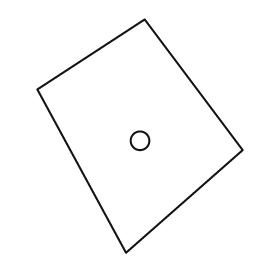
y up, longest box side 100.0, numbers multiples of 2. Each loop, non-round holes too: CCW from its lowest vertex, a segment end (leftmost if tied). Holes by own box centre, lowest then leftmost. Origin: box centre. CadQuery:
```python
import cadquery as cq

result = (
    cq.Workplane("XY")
    .moveTo(-6.0, -50.0)
    .lineTo(44.0, -6.0)
    .lineTo(2.0, 50.0)
    .lineTo(-44.0, 20.0)
    .close()
    .moveTo(0.0, -2.0)
    .circle(4.0)
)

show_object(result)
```